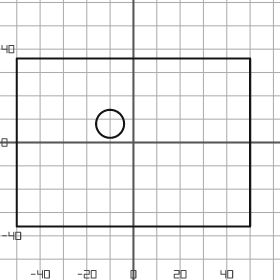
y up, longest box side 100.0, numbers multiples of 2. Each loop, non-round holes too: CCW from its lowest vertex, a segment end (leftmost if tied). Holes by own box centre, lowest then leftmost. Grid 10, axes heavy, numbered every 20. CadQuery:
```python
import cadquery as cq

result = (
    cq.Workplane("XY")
    .moveTo(-50.0, -36.0)
    .lineTo(50.0, -36.0)
    .lineTo(50.0, 36.0)
    .lineTo(-50.0, 36.0)
    .close()
    .moveTo(-10.0, 8.0)
    .circle(6.0)
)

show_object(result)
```